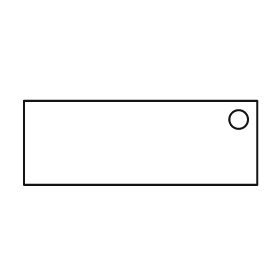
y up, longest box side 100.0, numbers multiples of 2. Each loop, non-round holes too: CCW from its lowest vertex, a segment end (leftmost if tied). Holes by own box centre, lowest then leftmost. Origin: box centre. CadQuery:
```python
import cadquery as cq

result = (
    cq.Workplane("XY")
    .moveTo(-50.0, -18.0)
    .lineTo(50.0, -18.0)
    .lineTo(50.0, 18.0)
    .lineTo(-50.0, 18.0)
    .close()
    .moveTo(42.0, 10.0)
    .circle(4.0)
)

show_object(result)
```